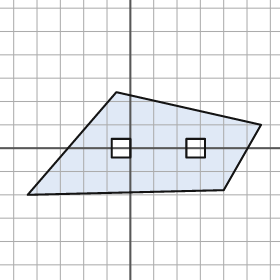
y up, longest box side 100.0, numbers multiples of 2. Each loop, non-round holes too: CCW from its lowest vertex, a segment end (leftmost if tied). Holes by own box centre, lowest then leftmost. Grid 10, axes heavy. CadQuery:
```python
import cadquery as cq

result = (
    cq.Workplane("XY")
    .moveTo(-44.0, -20.0)
    .lineTo(40.0, -18.0)
    .lineTo(56.0, 10.0)
    .lineTo(-6.0, 24.0)
    .close()
    .moveTo(-8.0, -4.0)
    .lineTo(0.0, -4.0)
    .lineTo(0.0, 4.0)
    .lineTo(-8.0, 4.0)
    .close()
    .moveTo(24.0, -4.0)
    .lineTo(32.0, -4.0)
    .lineTo(32.0, 4.0)
    .lineTo(24.0, 4.0)
    .close()
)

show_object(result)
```